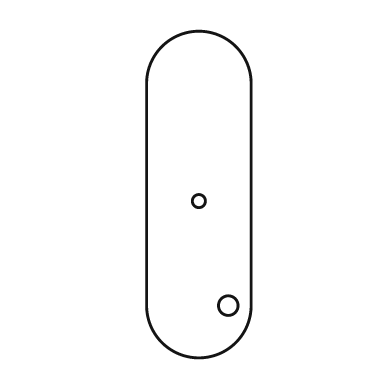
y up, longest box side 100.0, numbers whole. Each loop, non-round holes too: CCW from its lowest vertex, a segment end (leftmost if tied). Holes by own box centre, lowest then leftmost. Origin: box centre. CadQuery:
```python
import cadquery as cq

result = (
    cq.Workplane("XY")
    .moveTo(-16.0, -34.0)
    .threePointArc((0.0, -50.0), (16.0, -34.0))
    .lineTo(16.0, 34.0)
    .threePointArc((0.0, 50.0), (-16.0, 34.0))
    .close()
    .moveTo(9.0, -34.0)
    .circle(3.0)
    .moveTo(0.0, -2.0)
    .circle(2.0)
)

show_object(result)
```